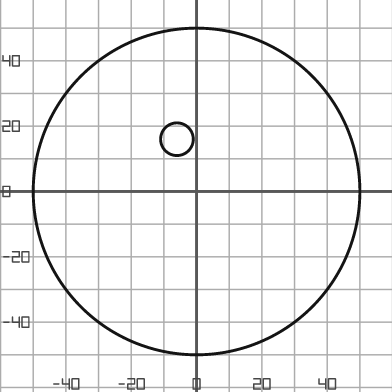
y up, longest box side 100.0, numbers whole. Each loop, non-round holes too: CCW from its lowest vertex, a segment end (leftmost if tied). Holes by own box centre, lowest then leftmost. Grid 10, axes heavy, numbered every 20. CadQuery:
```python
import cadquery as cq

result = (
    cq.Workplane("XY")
    .moveTo(0.0, 0.0)
    .circle(50.0)
    .moveTo(-6.0, 16.0)
    .circle(5.0)
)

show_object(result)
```